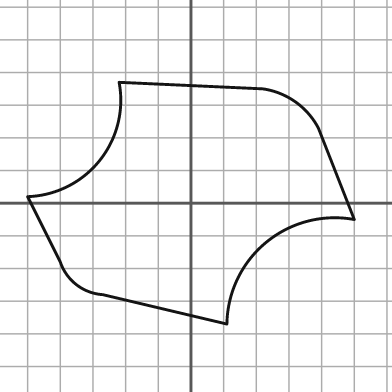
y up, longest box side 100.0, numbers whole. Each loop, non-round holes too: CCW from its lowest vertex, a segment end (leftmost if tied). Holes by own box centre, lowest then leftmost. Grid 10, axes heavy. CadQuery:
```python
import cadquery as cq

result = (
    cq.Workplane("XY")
    .moveTo(11.0, -37.0)
    .threePointArc((23.0, -12.0), (50.0, -5.0))
    .lineTo(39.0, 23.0)
    .threePointArc((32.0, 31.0), (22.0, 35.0))
    .lineTo(-22.0, 37.0)
    .threePointArc((-28.0, 13.0), (-50.0, 2.0))
    .lineTo(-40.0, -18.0)
    .threePointArc((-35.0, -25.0), (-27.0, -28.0))
    .close()
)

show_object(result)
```